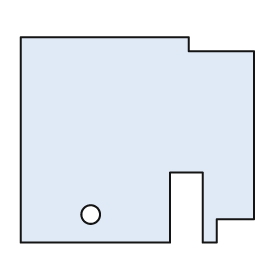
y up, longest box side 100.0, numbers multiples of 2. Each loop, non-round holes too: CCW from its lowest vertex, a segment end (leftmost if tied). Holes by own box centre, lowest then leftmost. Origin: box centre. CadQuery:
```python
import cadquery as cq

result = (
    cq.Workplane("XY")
    .moveTo(-50.0, -44.0)
    .lineTo(14.0, -44.0)
    .lineTo(14.0, -14.0)
    .lineTo(28.0, -14.0)
    .lineTo(28.0, -44.0)
    .lineTo(34.0, -44.0)
    .lineTo(34.0, -34.0)
    .lineTo(50.0, -34.0)
    .lineTo(50.0, 38.0)
    .lineTo(22.0, 38.0)
    .lineTo(22.0, 44.0)
    .lineTo(-50.0, 44.0)
    .close()
    .moveTo(-20.0, -32.0)
    .circle(4.0)
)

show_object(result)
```